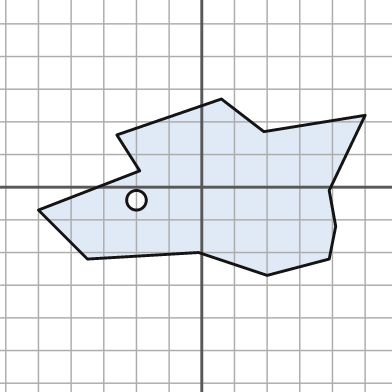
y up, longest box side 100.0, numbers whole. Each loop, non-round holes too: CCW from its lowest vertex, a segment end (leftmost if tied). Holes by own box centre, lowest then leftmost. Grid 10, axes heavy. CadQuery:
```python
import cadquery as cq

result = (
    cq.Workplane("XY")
    .moveTo(20.0, -27.0)
    .lineTo(39.0, -22.0)
    .lineTo(41.0, -12.0)
    .lineTo(39.0, -1.0)
    .lineTo(50.0, 22.0)
    .lineTo(19.0, 17.0)
    .lineTo(6.0, 27.0)
    .lineTo(-26.0, 16.0)
    .lineTo(-19.0, 5.0)
    .lineTo(-50.0, -7.0)
    .lineTo(-35.0, -22.0)
    .lineTo(-1.0, -20.0)
    .close()
    .moveTo(-20.0, -4.0)
    .circle(3.0)
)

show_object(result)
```